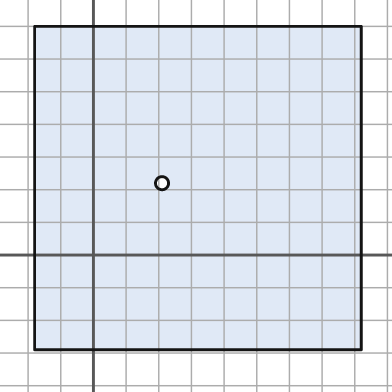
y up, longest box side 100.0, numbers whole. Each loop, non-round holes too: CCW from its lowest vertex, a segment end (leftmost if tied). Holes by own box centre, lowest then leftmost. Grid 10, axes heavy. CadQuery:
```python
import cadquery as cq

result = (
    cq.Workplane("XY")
    .moveTo(-18.0, -29.0)
    .lineTo(82.0, -29.0)
    .lineTo(82.0, 70.0)
    .lineTo(-18.0, 70.0)
    .close()
    .moveTo(21.0, 22.0)
    .circle(2.0)
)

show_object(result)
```